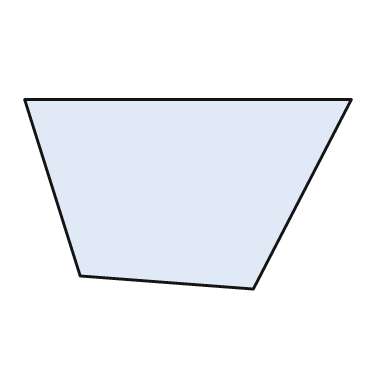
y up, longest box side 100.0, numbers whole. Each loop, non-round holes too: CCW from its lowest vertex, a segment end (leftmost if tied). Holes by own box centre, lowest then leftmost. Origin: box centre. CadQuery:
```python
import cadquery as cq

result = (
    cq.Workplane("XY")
    .moveTo(20.0, -29.0)
    .lineTo(50.0, 29.0)
    .lineTo(-50.0, 29.0)
    .lineTo(-33.0, -25.0)
    .close()
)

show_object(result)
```